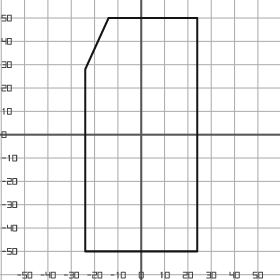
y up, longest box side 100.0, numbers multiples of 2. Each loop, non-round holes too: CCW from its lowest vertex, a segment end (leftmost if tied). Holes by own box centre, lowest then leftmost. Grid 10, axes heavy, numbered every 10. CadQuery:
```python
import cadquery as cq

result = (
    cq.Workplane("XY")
    .moveTo(-24.0, -50.0)
    .lineTo(24.0, -50.0)
    .lineTo(24.0, 50.0)
    .lineTo(-14.0, 50.0)
    .lineTo(-24.0, 28.0)
    .close()
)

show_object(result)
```